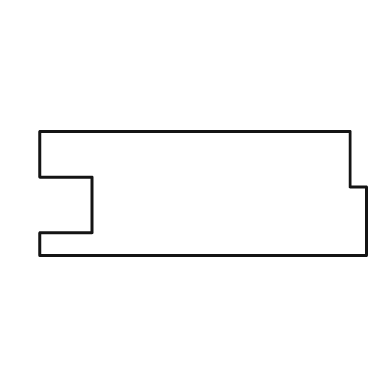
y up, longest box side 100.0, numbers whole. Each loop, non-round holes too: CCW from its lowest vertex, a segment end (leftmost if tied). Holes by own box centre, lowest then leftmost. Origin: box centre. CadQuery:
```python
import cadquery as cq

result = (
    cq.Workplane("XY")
    .moveTo(-50.0, -19.0)
    .lineTo(50.0, -19.0)
    .lineTo(50.0, 2.0)
    .lineTo(45.0, 2.0)
    .lineTo(45.0, 19.0)
    .lineTo(-50.0, 19.0)
    .lineTo(-50.0, 5.0)
    .lineTo(-34.0, 5.0)
    .lineTo(-34.0, -12.0)
    .lineTo(-50.0, -12.0)
    .close()
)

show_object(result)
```